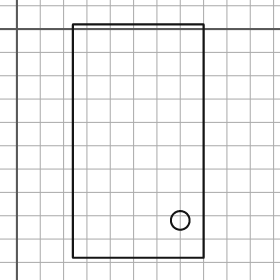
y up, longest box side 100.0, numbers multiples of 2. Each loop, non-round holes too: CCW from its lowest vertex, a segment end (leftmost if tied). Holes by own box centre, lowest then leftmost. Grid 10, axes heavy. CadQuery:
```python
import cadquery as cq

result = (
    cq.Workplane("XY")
    .moveTo(24.0, -98.0)
    .lineTo(80.0, -98.0)
    .lineTo(80.0, 2.0)
    .lineTo(24.0, 2.0)
    .close()
    .moveTo(70.0, -82.0)
    .circle(4.0)
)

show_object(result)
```